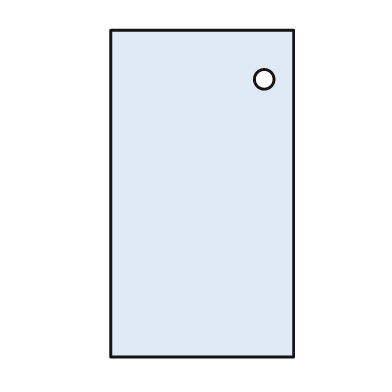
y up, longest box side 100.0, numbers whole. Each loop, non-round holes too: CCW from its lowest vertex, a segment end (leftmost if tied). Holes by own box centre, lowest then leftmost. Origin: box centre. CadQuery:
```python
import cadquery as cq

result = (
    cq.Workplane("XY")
    .moveTo(-28.0, -50.0)
    .lineTo(28.0, -50.0)
    .lineTo(28.0, 50.0)
    .lineTo(-28.0, 50.0)
    .close()
    .moveTo(19.0, 35.0)
    .circle(3.0)
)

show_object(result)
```